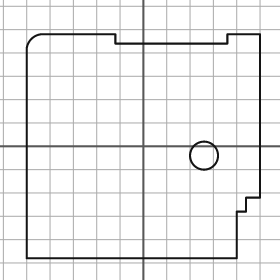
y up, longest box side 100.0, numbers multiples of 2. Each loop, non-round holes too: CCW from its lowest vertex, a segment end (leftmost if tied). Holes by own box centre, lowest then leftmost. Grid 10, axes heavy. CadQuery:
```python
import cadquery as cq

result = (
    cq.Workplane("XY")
    .moveTo(-50.0, -48.0)
    .lineTo(40.0, -48.0)
    .lineTo(40.0, -28.0)
    .lineTo(44.0, -28.0)
    .lineTo(44.0, -22.0)
    .lineTo(50.0, -22.0)
    .lineTo(50.0, 48.0)
    .lineTo(36.0, 48.0)
    .lineTo(36.0, 44.0)
    .lineTo(-12.0, 44.0)
    .lineTo(-12.0, 48.0)
    .lineTo(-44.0, 48.0)
    .threePointArc((-48.0, 46.0), (-50.0, 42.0))
    .close()
    .moveTo(26.0, -4.0)
    .circle(6.0)
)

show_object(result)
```